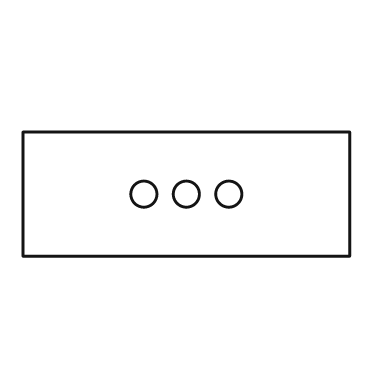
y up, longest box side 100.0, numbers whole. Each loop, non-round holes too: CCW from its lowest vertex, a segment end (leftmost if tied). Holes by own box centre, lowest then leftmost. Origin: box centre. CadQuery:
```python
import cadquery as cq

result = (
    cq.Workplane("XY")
    .moveTo(-50.0, -19.0)
    .lineTo(50.0, -19.0)
    .lineTo(50.0, 19.0)
    .lineTo(-50.0, 19.0)
    .close()
    .moveTo(-13.0, 0.0)
    .circle(4.0)
    .moveTo(0.0, 0.0)
    .circle(4.0)
    .moveTo(13.0, 0.0)
    .circle(4.0)
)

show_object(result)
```